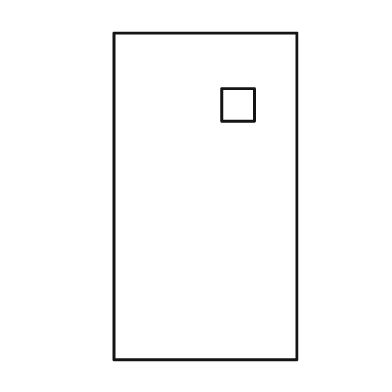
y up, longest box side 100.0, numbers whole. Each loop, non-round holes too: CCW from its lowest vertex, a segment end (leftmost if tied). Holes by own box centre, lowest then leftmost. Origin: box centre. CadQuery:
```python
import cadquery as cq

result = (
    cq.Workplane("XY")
    .moveTo(-28.0, -50.0)
    .lineTo(28.0, -50.0)
    .lineTo(28.0, 50.0)
    .lineTo(-28.0, 50.0)
    .close()
    .moveTo(5.0, 23.0)
    .lineTo(15.0, 23.0)
    .lineTo(15.0, 33.0)
    .lineTo(5.0, 33.0)
    .close()
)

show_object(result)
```